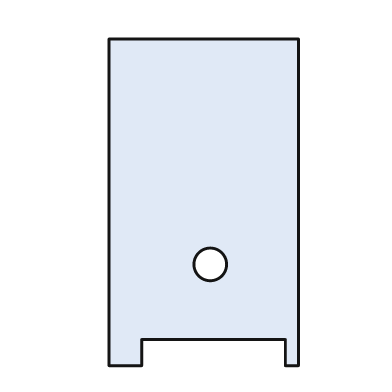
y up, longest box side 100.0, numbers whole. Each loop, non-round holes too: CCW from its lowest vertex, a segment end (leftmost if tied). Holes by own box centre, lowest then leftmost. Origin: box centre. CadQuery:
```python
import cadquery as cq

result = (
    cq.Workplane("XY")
    .moveTo(-29.0, -50.0)
    .lineTo(-19.0, -50.0)
    .lineTo(-19.0, -42.0)
    .lineTo(25.0, -42.0)
    .lineTo(25.0, -50.0)
    .lineTo(29.0, -50.0)
    .lineTo(29.0, 50.0)
    .lineTo(-29.0, 50.0)
    .close()
    .moveTo(2.0, -19.0)
    .circle(5.0)
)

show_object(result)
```